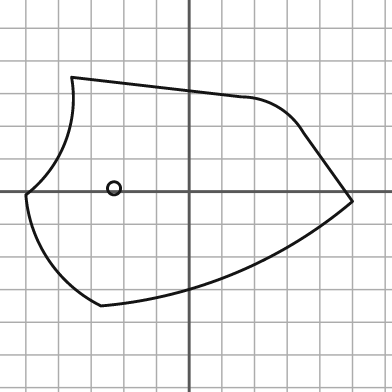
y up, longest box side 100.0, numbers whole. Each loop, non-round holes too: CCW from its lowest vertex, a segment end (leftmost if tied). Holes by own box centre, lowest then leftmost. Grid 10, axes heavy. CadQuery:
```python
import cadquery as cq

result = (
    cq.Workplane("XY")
    .moveTo(-27.0, -35.0)
    .threePointArc((14.0, -25.0), (50.0, -3.0))
    .lineTo(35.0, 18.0)
    .threePointArc((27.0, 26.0), (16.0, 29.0))
    .lineTo(-36.0, 35.0)
    .threePointArc((-38.0, 15.0), (-50.0, -1.0))
    .threePointArc((-43.0, -21.0), (-27.0, -35.0))
    .close()
    .moveTo(-23.0, 1.0)
    .circle(2.0)
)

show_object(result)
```